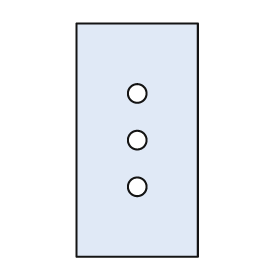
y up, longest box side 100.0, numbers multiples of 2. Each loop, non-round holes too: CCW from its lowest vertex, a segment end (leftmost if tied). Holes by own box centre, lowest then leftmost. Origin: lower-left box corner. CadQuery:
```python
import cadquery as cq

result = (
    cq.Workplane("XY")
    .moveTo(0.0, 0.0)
    .lineTo(52.0, 0.0)
    .lineTo(52.0, 100.0)
    .lineTo(0.0, 100.0)
    .close()
    .moveTo(26.0, 30.0)
    .circle(4.0)
    .moveTo(26.0, 50.0)
    .circle(4.0)
    .moveTo(26.0, 70.0)
    .circle(4.0)
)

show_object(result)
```